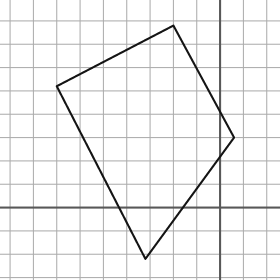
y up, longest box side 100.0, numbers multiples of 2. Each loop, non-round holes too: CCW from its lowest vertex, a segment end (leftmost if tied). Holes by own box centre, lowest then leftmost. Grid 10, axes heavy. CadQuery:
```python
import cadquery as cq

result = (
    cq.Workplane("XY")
    .moveTo(-32.0, -22.0)
    .lineTo(6.0, 30.0)
    .lineTo(-20.0, 78.0)
    .lineTo(-70.0, 52.0)
    .close()
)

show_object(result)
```